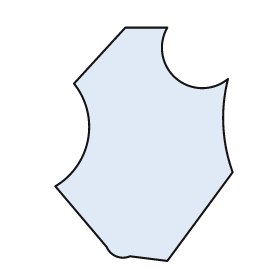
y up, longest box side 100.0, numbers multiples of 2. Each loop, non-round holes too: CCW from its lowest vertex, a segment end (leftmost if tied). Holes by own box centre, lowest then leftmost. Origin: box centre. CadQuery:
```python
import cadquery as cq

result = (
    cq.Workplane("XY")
    .moveTo(10.0, -50.0)
    .lineTo(38.0, -12.0)
    .threePointArc((34.0, 8.0), (36.0, 28.0))
    .threePointArc((14.0, 28.0), (10.0, 50.0))
    .lineTo(-8.0, 50.0)
    .lineTo(-30.0, 26.0)
    .threePointArc((-24.0, 2.0), (-38.0, -18.0))
    .lineTo(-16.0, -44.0)
    .threePointArc((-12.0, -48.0), (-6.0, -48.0))
    .close()
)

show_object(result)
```